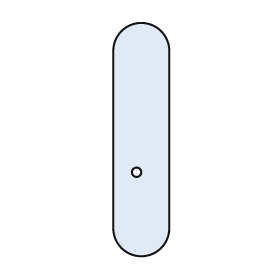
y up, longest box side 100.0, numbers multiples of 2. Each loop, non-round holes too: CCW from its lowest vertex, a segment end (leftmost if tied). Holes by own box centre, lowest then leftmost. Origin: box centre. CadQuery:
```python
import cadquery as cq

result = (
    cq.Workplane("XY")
    .moveTo(-12.0, -38.0)
    .threePointArc((0.0, -50.0), (12.0, -38.0))
    .lineTo(12.0, 38.0)
    .threePointArc((0.0, 50.0), (-12.0, 38.0))
    .close()
    .moveTo(-2.0, -14.0)
    .circle(2.0)
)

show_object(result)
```